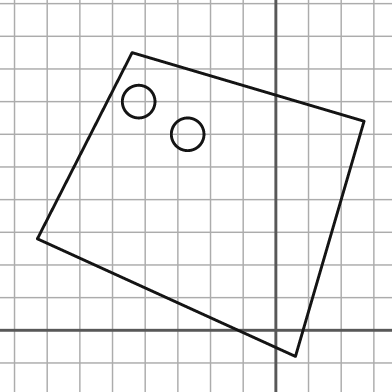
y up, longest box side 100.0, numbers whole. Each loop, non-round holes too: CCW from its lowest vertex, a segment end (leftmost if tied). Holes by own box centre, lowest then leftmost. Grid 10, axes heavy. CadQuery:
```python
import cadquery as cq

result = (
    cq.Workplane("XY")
    .moveTo(6.0, -8.0)
    .lineTo(27.0, 64.0)
    .lineTo(-44.0, 85.0)
    .lineTo(-73.0, 28.0)
    .close()
    .moveTo(-27.0, 60.0)
    .circle(5.0)
    .moveTo(-42.0, 70.0)
    .circle(5.0)
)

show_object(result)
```